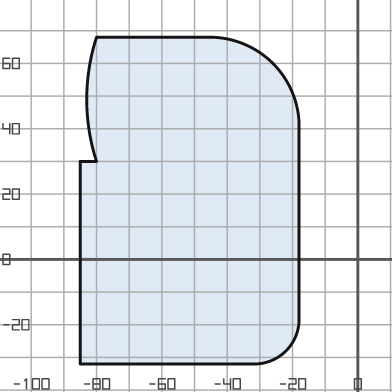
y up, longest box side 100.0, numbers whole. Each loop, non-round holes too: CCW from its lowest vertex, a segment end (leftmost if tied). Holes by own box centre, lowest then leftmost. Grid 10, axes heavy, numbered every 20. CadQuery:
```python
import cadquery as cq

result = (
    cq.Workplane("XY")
    .moveTo(-85.0, -32.0)
    .lineTo(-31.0, -32.0)
    .threePointArc((-22.0, -28.0), (-18.0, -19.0))
    .lineTo(-18.0, 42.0)
    .threePointArc((-26.0, 60.0), (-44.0, 68.0))
    .lineTo(-80.0, 68.0)
    .threePointArc((-83.0, 49.0), (-80.0, 30.0))
    .lineTo(-85.0, 30.0)
    .close()
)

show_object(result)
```